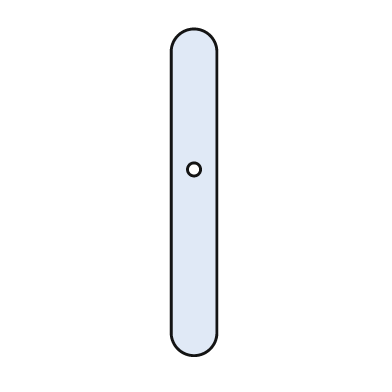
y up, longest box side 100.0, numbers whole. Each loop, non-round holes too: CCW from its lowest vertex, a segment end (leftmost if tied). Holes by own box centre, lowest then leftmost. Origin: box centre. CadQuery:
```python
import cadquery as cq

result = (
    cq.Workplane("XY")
    .moveTo(-7.0, -43.0)
    .threePointArc((0.0, -50.0), (7.0, -43.0))
    .lineTo(7.0, 43.0)
    .threePointArc((0.0, 50.0), (-7.0, 43.0))
    .close()
    .moveTo(0.0, 7.0)
    .circle(2.0)
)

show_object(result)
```